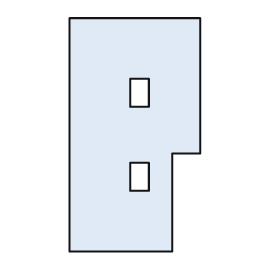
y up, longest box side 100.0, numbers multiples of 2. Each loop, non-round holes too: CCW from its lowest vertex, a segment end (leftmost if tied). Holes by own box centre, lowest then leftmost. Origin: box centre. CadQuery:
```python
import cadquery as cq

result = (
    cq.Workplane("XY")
    .moveTo(-28.0, -50.0)
    .lineTo(16.0, -50.0)
    .lineTo(16.0, -8.0)
    .lineTo(28.0, -8.0)
    .lineTo(28.0, 50.0)
    .lineTo(-28.0, 50.0)
    .close()
    .moveTo(-2.0, -24.0)
    .lineTo(6.0, -24.0)
    .lineTo(6.0, -12.0)
    .lineTo(-2.0, -12.0)
    .close()
    .moveTo(-2.0, 12.0)
    .lineTo(6.0, 12.0)
    .lineTo(6.0, 24.0)
    .lineTo(-2.0, 24.0)
    .close()
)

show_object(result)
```